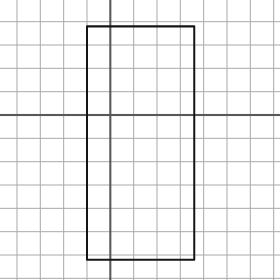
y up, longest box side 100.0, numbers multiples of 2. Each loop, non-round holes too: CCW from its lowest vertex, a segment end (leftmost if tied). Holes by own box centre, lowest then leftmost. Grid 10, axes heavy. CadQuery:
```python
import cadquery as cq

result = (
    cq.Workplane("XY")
    .moveTo(-10.0, -62.0)
    .lineTo(36.0, -62.0)
    .lineTo(36.0, 38.0)
    .lineTo(-10.0, 38.0)
    .close()
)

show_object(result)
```